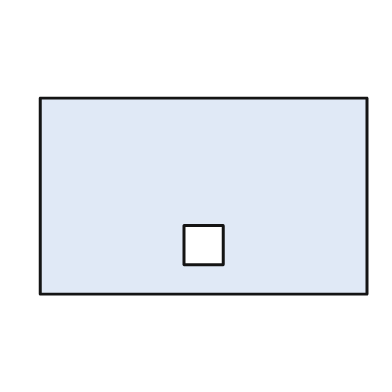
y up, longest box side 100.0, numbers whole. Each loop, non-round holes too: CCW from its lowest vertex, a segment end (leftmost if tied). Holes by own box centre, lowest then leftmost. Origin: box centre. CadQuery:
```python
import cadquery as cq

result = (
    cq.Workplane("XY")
    .moveTo(-50.0, -30.0)
    .lineTo(50.0, -30.0)
    .lineTo(50.0, 30.0)
    .lineTo(-50.0, 30.0)
    .close()
    .moveTo(-6.0, -21.0)
    .lineTo(6.0, -21.0)
    .lineTo(6.0, -9.0)
    .lineTo(-6.0, -9.0)
    .close()
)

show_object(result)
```